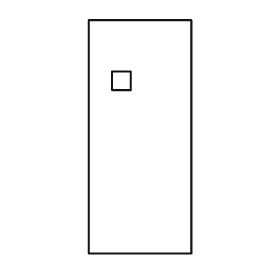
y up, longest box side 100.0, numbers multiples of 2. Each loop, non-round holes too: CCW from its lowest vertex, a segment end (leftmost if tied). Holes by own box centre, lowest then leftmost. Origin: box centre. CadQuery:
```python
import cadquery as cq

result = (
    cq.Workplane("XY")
    .moveTo(-22.0, -50.0)
    .lineTo(22.0, -50.0)
    .lineTo(22.0, 50.0)
    .lineTo(-22.0, 50.0)
    .close()
    .moveTo(-12.0, 20.0)
    .lineTo(-4.0, 20.0)
    .lineTo(-4.0, 28.0)
    .lineTo(-12.0, 28.0)
    .close()
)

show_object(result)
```